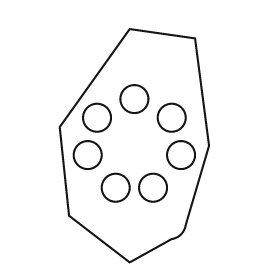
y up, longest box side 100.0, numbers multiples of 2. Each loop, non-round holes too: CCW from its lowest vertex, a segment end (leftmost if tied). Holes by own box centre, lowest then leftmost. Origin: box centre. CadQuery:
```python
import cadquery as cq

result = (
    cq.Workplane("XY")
    .moveTo(-2.0, -50.0)
    .lineTo(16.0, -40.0)
    .threePointArc((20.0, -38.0), (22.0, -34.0))
    .lineTo(32.0, 0.0)
    .lineTo(26.0, 46.0)
    .lineTo(-2.0, 50.0)
    .lineTo(-32.0, 8.0)
    .lineTo(-28.0, -30.0)
    .close()
    .moveTo(-8.0, -18.0)
    .circle(6.0)
    .moveTo(8.0, -18.0)
    .circle(6.0)
    .moveTo(-20.0, -4.0)
    .circle(6.0)
    .moveTo(20.0, -4.0)
    .circle(6.0)
    .moveTo(-16.0, 12.0)
    .circle(6.0)
    .moveTo(16.0, 12.0)
    .circle(6.0)
    .moveTo(0.0, 20.0)
    .circle(6.0)
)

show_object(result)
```